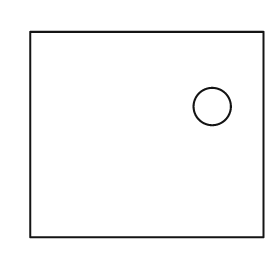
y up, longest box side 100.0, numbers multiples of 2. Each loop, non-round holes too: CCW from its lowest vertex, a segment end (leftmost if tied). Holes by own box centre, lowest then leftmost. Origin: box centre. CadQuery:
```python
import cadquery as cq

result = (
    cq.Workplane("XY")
    .moveTo(-50.0, -44.0)
    .lineTo(50.0, -44.0)
    .lineTo(50.0, 44.0)
    .lineTo(-50.0, 44.0)
    .close()
    .moveTo(28.0, 12.0)
    .circle(8.0)
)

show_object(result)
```